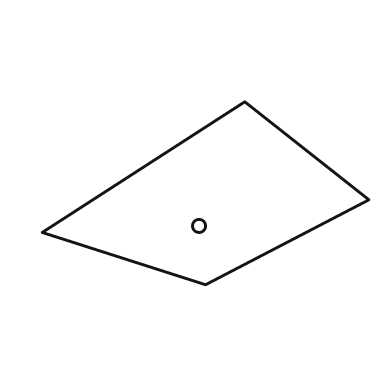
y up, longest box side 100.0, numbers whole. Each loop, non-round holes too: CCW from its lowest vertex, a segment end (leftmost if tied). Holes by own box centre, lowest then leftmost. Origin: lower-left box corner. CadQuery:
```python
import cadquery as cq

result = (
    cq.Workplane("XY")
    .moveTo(50.0, 0.0)
    .lineTo(100.0, 26.0)
    .lineTo(62.0, 56.0)
    .lineTo(0.0, 16.0)
    .close()
    .moveTo(48.0, 18.0)
    .circle(2.0)
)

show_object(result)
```